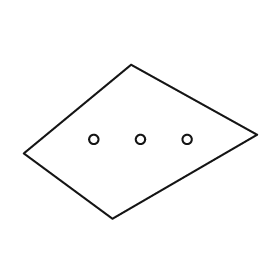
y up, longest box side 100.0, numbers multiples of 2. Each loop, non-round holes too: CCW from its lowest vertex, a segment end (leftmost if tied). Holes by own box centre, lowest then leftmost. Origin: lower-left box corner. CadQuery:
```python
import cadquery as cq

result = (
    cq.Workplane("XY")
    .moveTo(38.0, 0.0)
    .lineTo(100.0, 36.0)
    .lineTo(46.0, 66.0)
    .lineTo(0.0, 28.0)
    .close()
    .moveTo(30.0, 34.0)
    .circle(2.0)
    .moveTo(50.0, 34.0)
    .circle(2.0)
    .moveTo(70.0, 34.0)
    .circle(2.0)
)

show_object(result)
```